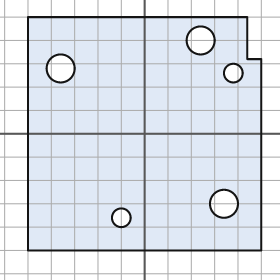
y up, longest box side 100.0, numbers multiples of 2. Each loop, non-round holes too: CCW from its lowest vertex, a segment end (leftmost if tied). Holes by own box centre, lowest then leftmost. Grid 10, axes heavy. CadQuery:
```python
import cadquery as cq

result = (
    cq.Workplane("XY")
    .moveTo(-50.0, -50.0)
    .lineTo(50.0, -50.0)
    .lineTo(50.0, 32.0)
    .lineTo(44.0, 32.0)
    .lineTo(44.0, 50.0)
    .lineTo(-50.0, 50.0)
    .close()
    .moveTo(-10.0, -36.0)
    .circle(4.0)
    .moveTo(34.0, -30.0)
    .circle(6.0)
    .moveTo(38.0, 26.0)
    .circle(4.0)
    .moveTo(-36.0, 28.0)
    .circle(6.0)
    .moveTo(24.0, 40.0)
    .circle(6.0)
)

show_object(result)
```